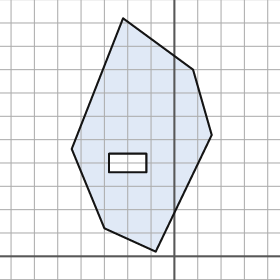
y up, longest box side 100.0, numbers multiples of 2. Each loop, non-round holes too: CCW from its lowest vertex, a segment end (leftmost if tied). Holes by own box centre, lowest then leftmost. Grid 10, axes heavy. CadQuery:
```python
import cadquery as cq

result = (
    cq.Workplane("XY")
    .moveTo(-8.0, 2.0)
    .lineTo(16.0, 52.0)
    .lineTo(8.0, 80.0)
    .lineTo(-22.0, 102.0)
    .lineTo(-44.0, 46.0)
    .lineTo(-30.0, 12.0)
    .close()
    .moveTo(-28.0, 36.0)
    .lineTo(-12.0, 36.0)
    .lineTo(-12.0, 44.0)
    .lineTo(-28.0, 44.0)
    .close()
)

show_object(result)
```